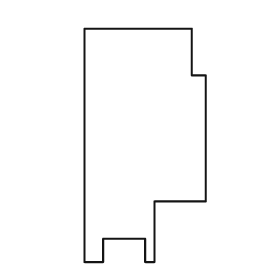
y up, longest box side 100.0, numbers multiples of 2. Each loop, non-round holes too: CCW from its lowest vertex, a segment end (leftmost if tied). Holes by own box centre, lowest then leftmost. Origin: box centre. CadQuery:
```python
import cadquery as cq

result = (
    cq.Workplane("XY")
    .moveTo(-26.0, -50.0)
    .lineTo(-18.0, -50.0)
    .lineTo(-18.0, -40.0)
    .lineTo(0.0, -40.0)
    .lineTo(0.0, -50.0)
    .lineTo(4.0, -50.0)
    .lineTo(4.0, -24.0)
    .lineTo(26.0, -24.0)
    .lineTo(26.0, 30.0)
    .lineTo(20.0, 30.0)
    .lineTo(20.0, 50.0)
    .lineTo(-26.0, 50.0)
    .close()
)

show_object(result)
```